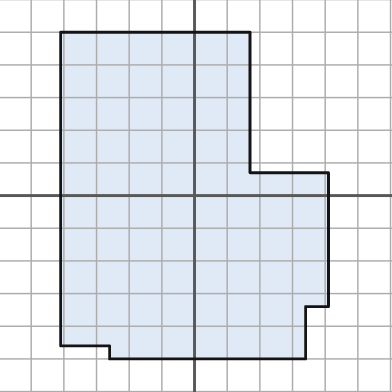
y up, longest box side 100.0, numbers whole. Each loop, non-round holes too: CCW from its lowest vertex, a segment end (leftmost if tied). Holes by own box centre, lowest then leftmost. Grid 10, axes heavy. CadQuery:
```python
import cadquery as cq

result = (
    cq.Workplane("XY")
    .moveTo(-26.0, -50.0)
    .lineTo(34.0, -50.0)
    .lineTo(34.0, -34.0)
    .lineTo(41.0, -34.0)
    .lineTo(41.0, 7.0)
    .lineTo(17.0, 7.0)
    .lineTo(17.0, 50.0)
    .lineTo(-41.0, 50.0)
    .lineTo(-41.0, -46.0)
    .lineTo(-26.0, -46.0)
    .close()
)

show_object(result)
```